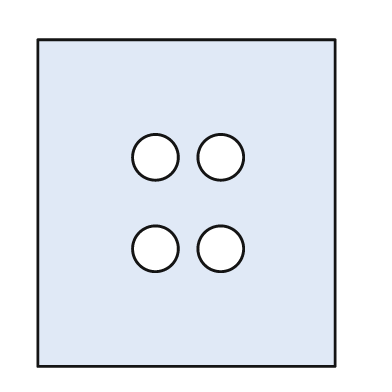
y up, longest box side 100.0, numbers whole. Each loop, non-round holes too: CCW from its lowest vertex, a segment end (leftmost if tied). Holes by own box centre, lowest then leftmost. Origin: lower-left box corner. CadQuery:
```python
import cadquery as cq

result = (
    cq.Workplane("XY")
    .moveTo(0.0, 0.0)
    .lineTo(91.0, 0.0)
    .lineTo(91.0, 100.0)
    .lineTo(0.0, 100.0)
    .close()
    .moveTo(36.0, 36.0)
    .circle(7.0)
    .moveTo(56.0, 36.0)
    .circle(7.0)
    .moveTo(36.0, 64.0)
    .circle(7.0)
    .moveTo(56.0, 64.0)
    .circle(7.0)
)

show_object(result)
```